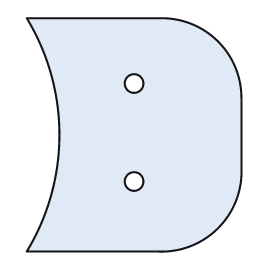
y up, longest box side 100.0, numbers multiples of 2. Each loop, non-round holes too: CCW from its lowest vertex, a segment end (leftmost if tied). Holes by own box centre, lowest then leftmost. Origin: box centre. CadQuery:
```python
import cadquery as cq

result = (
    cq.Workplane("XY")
    .moveTo(-46.0, -50.0)
    .lineTo(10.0, -50.0)
    .threePointArc((36.0, -40.0), (46.0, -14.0))
    .lineTo(46.0, 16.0)
    .threePointArc((36.0, 40.0), (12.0, 50.0))
    .lineTo(-46.0, 50.0)
    .threePointArc((-32.0, 0.0), (-46.0, -50.0))
    .close()
    .moveTo(0.0, -20.0)
    .circle(4.0)
    .moveTo(0.0, 22.0)
    .circle(4.0)
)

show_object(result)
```